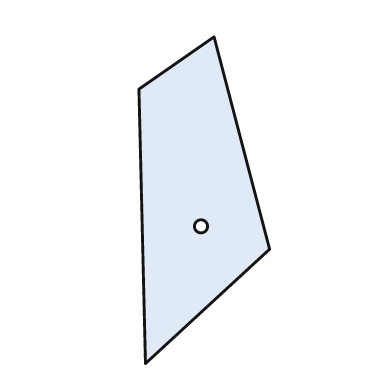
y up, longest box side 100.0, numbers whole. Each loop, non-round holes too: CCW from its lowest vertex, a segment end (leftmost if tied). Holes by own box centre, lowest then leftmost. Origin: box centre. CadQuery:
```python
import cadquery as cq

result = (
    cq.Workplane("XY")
    .moveTo(-18.0, -50.0)
    .lineTo(20.0, -15.0)
    .lineTo(3.0, 50.0)
    .lineTo(-20.0, 34.0)
    .close()
    .moveTo(-1.0, -8.0)
    .circle(2.0)
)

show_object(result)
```